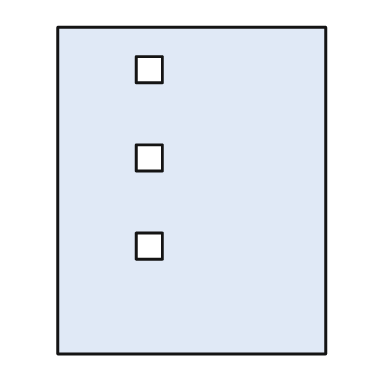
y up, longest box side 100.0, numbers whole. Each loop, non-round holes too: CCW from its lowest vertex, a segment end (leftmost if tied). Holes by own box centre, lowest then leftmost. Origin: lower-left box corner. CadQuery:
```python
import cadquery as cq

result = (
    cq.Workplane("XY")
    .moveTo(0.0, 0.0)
    .lineTo(82.0, 0.0)
    .lineTo(82.0, 100.0)
    .lineTo(0.0, 100.0)
    .close()
    .moveTo(24.0, 29.0)
    .lineTo(32.0, 29.0)
    .lineTo(32.0, 37.0)
    .lineTo(24.0, 37.0)
    .close()
    .moveTo(24.0, 56.0)
    .lineTo(32.0, 56.0)
    .lineTo(32.0, 64.0)
    .lineTo(24.0, 64.0)
    .close()
    .moveTo(24.0, 83.0)
    .lineTo(32.0, 83.0)
    .lineTo(32.0, 91.0)
    .lineTo(24.0, 91.0)
    .close()
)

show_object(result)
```